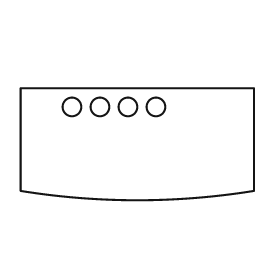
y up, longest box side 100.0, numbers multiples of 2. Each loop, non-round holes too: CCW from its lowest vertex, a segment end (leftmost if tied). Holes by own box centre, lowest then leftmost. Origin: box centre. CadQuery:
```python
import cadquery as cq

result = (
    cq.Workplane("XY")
    .moveTo(-50.0, -20.0)
    .threePointArc((0.0, -24.0), (50.0, -20.0))
    .lineTo(50.0, 24.0)
    .lineTo(-50.0, 24.0)
    .close()
    .moveTo(-28.0, 16.0)
    .circle(4.0)
    .moveTo(-16.0, 16.0)
    .circle(4.0)
    .moveTo(-4.0, 16.0)
    .circle(4.0)
    .moveTo(8.0, 16.0)
    .circle(4.0)
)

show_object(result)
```